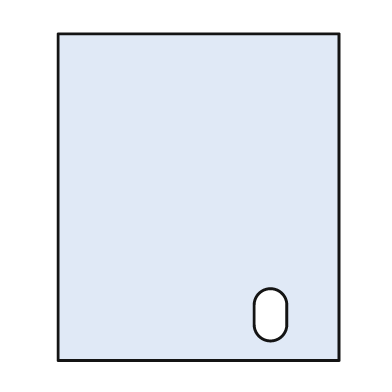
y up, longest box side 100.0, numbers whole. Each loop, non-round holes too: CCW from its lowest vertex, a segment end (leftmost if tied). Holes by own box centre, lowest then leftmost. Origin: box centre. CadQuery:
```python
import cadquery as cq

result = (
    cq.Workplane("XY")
    .moveTo(-43.0, -50.0)
    .lineTo(43.0, -50.0)
    .lineTo(43.0, 50.0)
    .lineTo(-43.0, 50.0)
    .close()
    .moveTo(17.0, -39.0)
    .threePointArc((22.0, -44.0), (27.0, -39.0))
    .lineTo(27.0, -33.0)
    .threePointArc((22.0, -28.0), (17.0, -33.0))
    .close()
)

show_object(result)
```